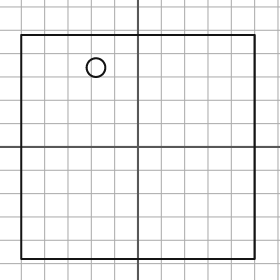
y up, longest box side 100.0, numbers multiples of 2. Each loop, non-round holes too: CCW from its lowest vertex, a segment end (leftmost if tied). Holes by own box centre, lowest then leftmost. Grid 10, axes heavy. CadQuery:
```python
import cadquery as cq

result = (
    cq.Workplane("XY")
    .moveTo(-50.0, -48.0)
    .lineTo(50.0, -48.0)
    .lineTo(50.0, 48.0)
    .lineTo(-50.0, 48.0)
    .close()
    .moveTo(-18.0, 34.0)
    .circle(4.0)
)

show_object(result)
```